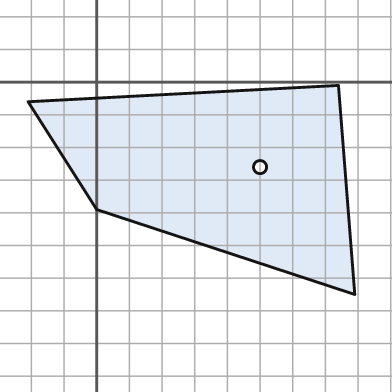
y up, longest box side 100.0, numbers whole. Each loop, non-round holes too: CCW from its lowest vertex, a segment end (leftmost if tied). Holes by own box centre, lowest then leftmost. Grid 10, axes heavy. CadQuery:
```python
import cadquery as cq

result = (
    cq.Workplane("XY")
    .moveTo(79.0, -65.0)
    .lineTo(74.0, -1.0)
    .lineTo(-21.0, -6.0)
    .lineTo(0.0, -39.0)
    .close()
    .moveTo(50.0, -26.0)
    .circle(2.0)
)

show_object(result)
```